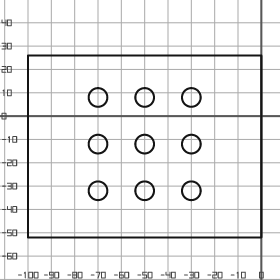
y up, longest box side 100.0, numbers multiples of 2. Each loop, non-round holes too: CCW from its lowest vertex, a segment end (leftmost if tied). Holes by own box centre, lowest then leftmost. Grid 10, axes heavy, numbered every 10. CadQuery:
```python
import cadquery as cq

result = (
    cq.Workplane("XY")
    .moveTo(-100.0, -52.0)
    .lineTo(0.0, -52.0)
    .lineTo(0.0, 26.0)
    .lineTo(-100.0, 26.0)
    .close()
    .moveTo(-70.0, -32.0)
    .circle(4.0)
    .moveTo(-50.0, -32.0)
    .circle(4.0)
    .moveTo(-30.0, -32.0)
    .circle(4.0)
    .moveTo(-70.0, -12.0)
    .circle(4.0)
    .moveTo(-50.0, -12.0)
    .circle(4.0)
    .moveTo(-30.0, -12.0)
    .circle(4.0)
    .moveTo(-70.0, 8.0)
    .circle(4.0)
    .moveTo(-50.0, 8.0)
    .circle(4.0)
    .moveTo(-30.0, 8.0)
    .circle(4.0)
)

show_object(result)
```